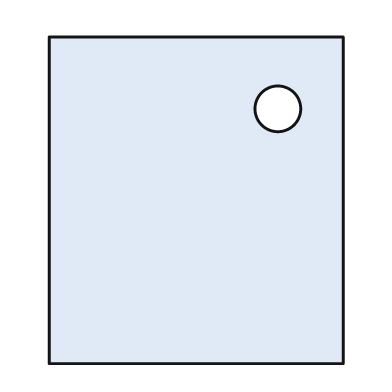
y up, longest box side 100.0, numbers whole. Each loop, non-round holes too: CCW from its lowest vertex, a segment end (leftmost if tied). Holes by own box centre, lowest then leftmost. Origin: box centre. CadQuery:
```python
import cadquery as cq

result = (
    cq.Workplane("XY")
    .moveTo(-45.0, -50.0)
    .lineTo(45.0, -50.0)
    .lineTo(45.0, 50.0)
    .lineTo(-45.0, 50.0)
    .close()
    .moveTo(25.0, 28.0)
    .circle(7.0)
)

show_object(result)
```